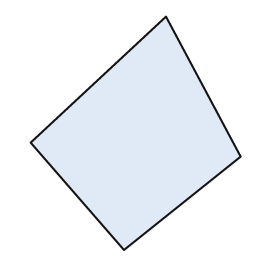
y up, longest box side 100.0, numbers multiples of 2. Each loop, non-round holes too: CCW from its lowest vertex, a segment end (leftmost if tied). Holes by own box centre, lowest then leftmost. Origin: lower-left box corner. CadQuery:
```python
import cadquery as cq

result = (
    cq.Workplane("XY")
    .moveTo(40.0, 0.0)
    .lineTo(90.0, 40.0)
    .lineTo(58.0, 100.0)
    .lineTo(0.0, 46.0)
    .close()
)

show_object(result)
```